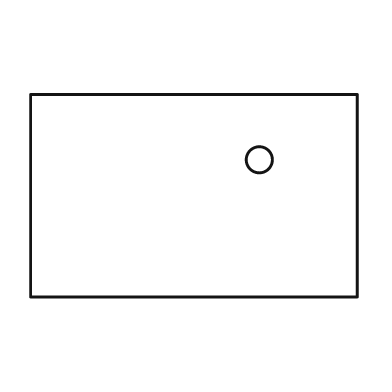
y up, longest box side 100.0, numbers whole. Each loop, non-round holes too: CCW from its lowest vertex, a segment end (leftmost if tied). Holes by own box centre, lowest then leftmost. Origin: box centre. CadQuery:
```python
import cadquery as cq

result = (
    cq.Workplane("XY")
    .moveTo(-50.0, -31.0)
    .lineTo(50.0, -31.0)
    .lineTo(50.0, 31.0)
    .lineTo(-50.0, 31.0)
    .close()
    .moveTo(20.0, 11.0)
    .circle(4.0)
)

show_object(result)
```